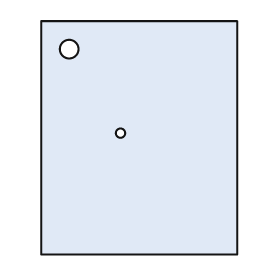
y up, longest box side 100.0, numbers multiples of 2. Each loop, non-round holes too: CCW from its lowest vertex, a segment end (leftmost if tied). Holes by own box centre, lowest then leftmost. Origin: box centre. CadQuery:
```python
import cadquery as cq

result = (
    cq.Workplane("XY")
    .moveTo(-42.0, -50.0)
    .lineTo(42.0, -50.0)
    .lineTo(42.0, 50.0)
    .lineTo(-42.0, 50.0)
    .close()
    .moveTo(-8.0, 2.0)
    .circle(2.0)
    .moveTo(-30.0, 38.0)
    .circle(4.0)
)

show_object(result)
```